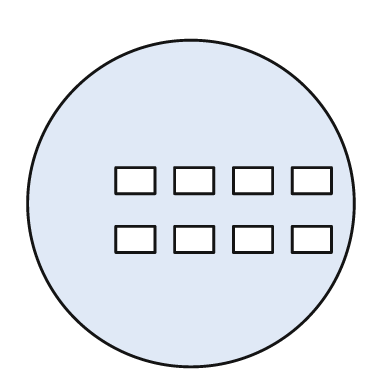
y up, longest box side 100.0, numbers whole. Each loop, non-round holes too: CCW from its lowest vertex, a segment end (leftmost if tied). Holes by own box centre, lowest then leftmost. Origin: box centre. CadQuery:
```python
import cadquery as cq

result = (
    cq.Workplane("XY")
    .moveTo(0.0, 0.0)
    .circle(50.0)
    .moveTo(-23.0, -15.0)
    .lineTo(-11.0, -15.0)
    .lineTo(-11.0, -7.0)
    .lineTo(-23.0, -7.0)
    .close()
    .moveTo(-5.0, -15.0)
    .lineTo(7.0, -15.0)
    .lineTo(7.0, -7.0)
    .lineTo(-5.0, -7.0)
    .close()
    .moveTo(13.0, -15.0)
    .lineTo(25.0, -15.0)
    .lineTo(25.0, -7.0)
    .lineTo(13.0, -7.0)
    .close()
    .moveTo(31.0, -15.0)
    .lineTo(43.0, -15.0)
    .lineTo(43.0, -7.0)
    .lineTo(31.0, -7.0)
    .close()
    .moveTo(-23.0, 3.0)
    .lineTo(-11.0, 3.0)
    .lineTo(-11.0, 11.0)
    .lineTo(-23.0, 11.0)
    .close()
    .moveTo(-5.0, 3.0)
    .lineTo(7.0, 3.0)
    .lineTo(7.0, 11.0)
    .lineTo(-5.0, 11.0)
    .close()
    .moveTo(13.0, 3.0)
    .lineTo(25.0, 3.0)
    .lineTo(25.0, 11.0)
    .lineTo(13.0, 11.0)
    .close()
    .moveTo(31.0, 3.0)
    .lineTo(43.0, 3.0)
    .lineTo(43.0, 11.0)
    .lineTo(31.0, 11.0)
    .close()
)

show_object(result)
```